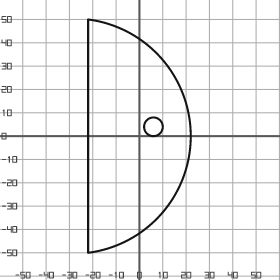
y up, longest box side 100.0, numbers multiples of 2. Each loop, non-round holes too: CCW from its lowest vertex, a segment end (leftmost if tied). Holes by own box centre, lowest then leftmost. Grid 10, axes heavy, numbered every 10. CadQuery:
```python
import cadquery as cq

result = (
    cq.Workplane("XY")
    .moveTo(-22.0, -50.0)
    .threePointArc((22.0, 0.0), (-22.0, 50.0))
    .close()
    .moveTo(6.0, 4.0)
    .circle(4.0)
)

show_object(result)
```